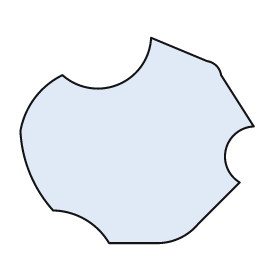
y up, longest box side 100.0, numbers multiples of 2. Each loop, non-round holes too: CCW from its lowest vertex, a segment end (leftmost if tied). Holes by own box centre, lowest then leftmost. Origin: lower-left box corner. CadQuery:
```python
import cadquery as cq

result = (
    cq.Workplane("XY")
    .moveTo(38.0, 0.0)
    .lineTo(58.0, 0.0)
    .threePointArc((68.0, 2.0), (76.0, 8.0))
    .lineTo(94.0, 26.0)
    .threePointArc((88.0, 40.0), (100.0, 50.0))
    .lineTo(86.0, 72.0)
    .threePointArc((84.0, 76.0), (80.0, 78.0))
    .lineTo(56.0, 88.0)
    .threePointArc((42.0, 68.0), (18.0, 72.0))
    .threePointArc((6.0, 62.0), (0.0, 48.0))
    .threePointArc((4.0, 30.0), (14.0, 14.0))
    .threePointArc((28.0, 10.0), (38.0, 0.0))
    .close()
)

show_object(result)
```